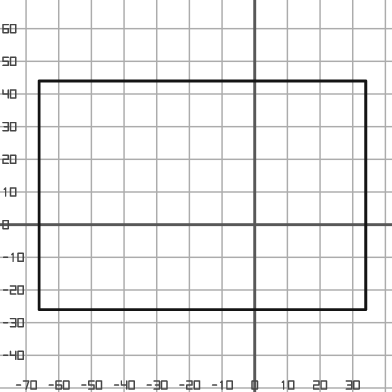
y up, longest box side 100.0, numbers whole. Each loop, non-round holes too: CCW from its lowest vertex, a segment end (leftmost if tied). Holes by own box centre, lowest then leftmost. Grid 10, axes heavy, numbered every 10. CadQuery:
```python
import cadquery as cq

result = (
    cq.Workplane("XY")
    .moveTo(-66.0, -26.0)
    .lineTo(34.0, -26.0)
    .lineTo(34.0, 44.0)
    .lineTo(-66.0, 44.0)
    .close()
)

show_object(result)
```